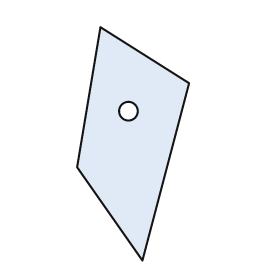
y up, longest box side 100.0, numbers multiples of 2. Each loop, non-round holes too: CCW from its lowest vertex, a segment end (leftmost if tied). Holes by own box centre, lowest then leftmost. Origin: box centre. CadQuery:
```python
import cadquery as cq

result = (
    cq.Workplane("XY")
    .moveTo(4.0, -50.0)
    .lineTo(24.0, 26.0)
    .lineTo(-14.0, 50.0)
    .lineTo(-24.0, -10.0)
    .close()
    .moveTo(-2.0, 14.0)
    .circle(4.0)
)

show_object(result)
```